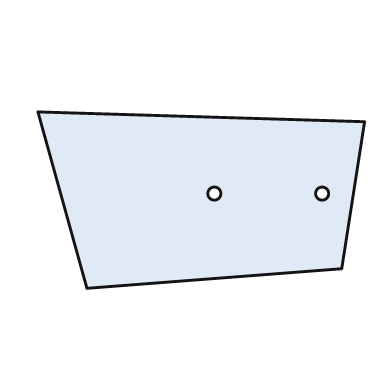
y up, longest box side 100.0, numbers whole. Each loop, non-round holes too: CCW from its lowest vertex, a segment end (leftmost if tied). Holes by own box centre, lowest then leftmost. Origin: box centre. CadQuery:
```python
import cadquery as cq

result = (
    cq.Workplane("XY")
    .moveTo(-35.0, -27.0)
    .lineTo(43.0, -21.0)
    .lineTo(50.0, 24.0)
    .lineTo(-50.0, 27.0)
    .close()
    .moveTo(4.0, 2.0)
    .circle(2.0)
    .moveTo(37.0, 2.0)
    .circle(2.0)
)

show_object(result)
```